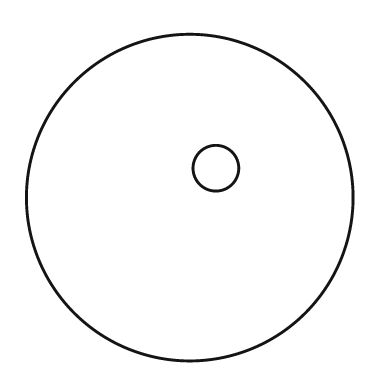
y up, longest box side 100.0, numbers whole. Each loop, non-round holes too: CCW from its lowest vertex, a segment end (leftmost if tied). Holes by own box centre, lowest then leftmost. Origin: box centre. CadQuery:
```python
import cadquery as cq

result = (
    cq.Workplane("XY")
    .moveTo(0.0, 0.0)
    .circle(50.0)
    .moveTo(8.0, 9.0)
    .circle(7.0)
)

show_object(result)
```